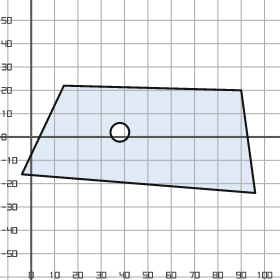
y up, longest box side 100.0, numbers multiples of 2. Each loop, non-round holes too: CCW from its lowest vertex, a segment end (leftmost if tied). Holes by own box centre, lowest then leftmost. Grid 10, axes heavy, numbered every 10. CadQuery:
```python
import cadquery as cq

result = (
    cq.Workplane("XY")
    .moveTo(96.0, -24.0)
    .lineTo(90.0, 20.0)
    .lineTo(14.0, 22.0)
    .lineTo(-4.0, -16.0)
    .close()
    .moveTo(38.0, 2.0)
    .circle(4.0)
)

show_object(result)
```